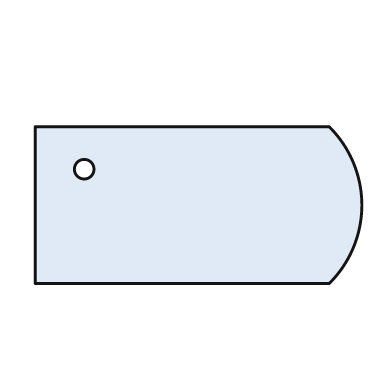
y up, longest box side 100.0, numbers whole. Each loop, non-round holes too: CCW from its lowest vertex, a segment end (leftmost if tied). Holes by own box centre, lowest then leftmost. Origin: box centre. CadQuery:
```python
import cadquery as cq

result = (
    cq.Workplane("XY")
    .moveTo(-50.0, -24.0)
    .lineTo(40.0, -24.0)
    .threePointArc((50.0, 0.0), (40.0, 24.0))
    .lineTo(-50.0, 24.0)
    .close()
    .moveTo(-35.0, 11.0)
    .circle(3.0)
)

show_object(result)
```